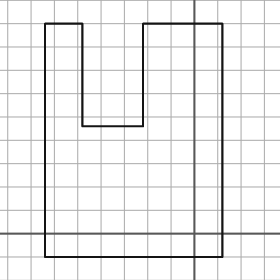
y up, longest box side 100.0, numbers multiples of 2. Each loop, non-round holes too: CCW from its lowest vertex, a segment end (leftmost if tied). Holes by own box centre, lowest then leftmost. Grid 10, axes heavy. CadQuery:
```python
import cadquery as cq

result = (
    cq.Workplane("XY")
    .moveTo(-64.0, -10.0)
    .lineTo(12.0, -10.0)
    .lineTo(12.0, 90.0)
    .lineTo(-22.0, 90.0)
    .lineTo(-22.0, 46.0)
    .lineTo(-48.0, 46.0)
    .lineTo(-48.0, 90.0)
    .lineTo(-64.0, 90.0)
    .close()
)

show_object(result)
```